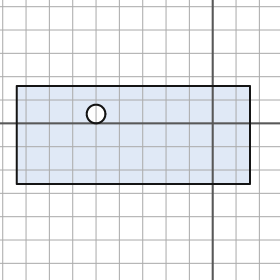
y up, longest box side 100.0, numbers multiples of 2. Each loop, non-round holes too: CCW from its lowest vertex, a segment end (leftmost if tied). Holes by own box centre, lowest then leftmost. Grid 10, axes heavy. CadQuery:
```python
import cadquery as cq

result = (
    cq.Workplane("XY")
    .moveTo(-84.0, -26.0)
    .lineTo(16.0, -26.0)
    .lineTo(16.0, 16.0)
    .lineTo(-84.0, 16.0)
    .close()
    .moveTo(-50.0, 4.0)
    .circle(4.0)
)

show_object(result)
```